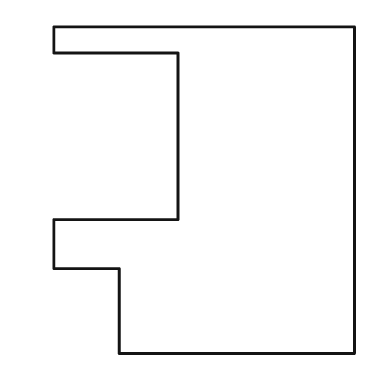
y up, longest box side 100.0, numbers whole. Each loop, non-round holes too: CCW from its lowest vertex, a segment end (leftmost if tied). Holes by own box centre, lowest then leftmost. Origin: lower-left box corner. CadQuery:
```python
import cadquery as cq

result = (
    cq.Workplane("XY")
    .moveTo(20.0, 0.0)
    .lineTo(92.0, 0.0)
    .lineTo(92.0, 100.0)
    .lineTo(0.0, 100.0)
    .lineTo(0.0, 92.0)
    .lineTo(38.0, 92.0)
    .lineTo(38.0, 41.0)
    .lineTo(0.0, 41.0)
    .lineTo(0.0, 26.0)
    .lineTo(20.0, 26.0)
    .close()
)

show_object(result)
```